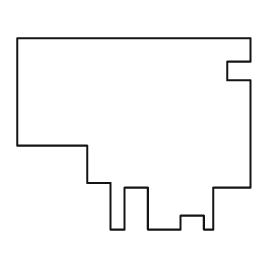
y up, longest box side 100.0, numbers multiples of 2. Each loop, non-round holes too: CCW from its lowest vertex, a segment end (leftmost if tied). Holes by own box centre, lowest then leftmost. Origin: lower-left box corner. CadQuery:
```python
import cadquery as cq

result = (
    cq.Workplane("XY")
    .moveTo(40.0, 0.0)
    .lineTo(46.0, 0.0)
    .lineTo(46.0, 18.0)
    .lineTo(56.0, 18.0)
    .lineTo(56.0, 0.0)
    .lineTo(70.0, 0.0)
    .lineTo(70.0, 6.0)
    .lineTo(80.0, 6.0)
    .lineTo(80.0, 0.0)
    .lineTo(84.0, 0.0)
    .lineTo(84.0, 18.0)
    .lineTo(100.0, 18.0)
    .lineTo(100.0, 64.0)
    .lineTo(90.0, 64.0)
    .lineTo(90.0, 72.0)
    .lineTo(100.0, 72.0)
    .lineTo(100.0, 82.0)
    .lineTo(0.0, 82.0)
    .lineTo(0.0, 36.0)
    .lineTo(30.0, 36.0)
    .lineTo(30.0, 20.0)
    .lineTo(40.0, 20.0)
    .close()
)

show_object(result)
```